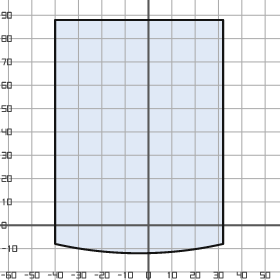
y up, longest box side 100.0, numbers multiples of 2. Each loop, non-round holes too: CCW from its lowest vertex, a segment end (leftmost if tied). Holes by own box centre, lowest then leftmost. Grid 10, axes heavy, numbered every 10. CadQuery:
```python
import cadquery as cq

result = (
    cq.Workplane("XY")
    .moveTo(-40.0, -8.0)
    .threePointArc((-4.0, -12.0), (32.0, -8.0))
    .lineTo(32.0, 88.0)
    .lineTo(-40.0, 88.0)
    .close()
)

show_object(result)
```